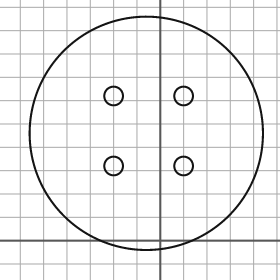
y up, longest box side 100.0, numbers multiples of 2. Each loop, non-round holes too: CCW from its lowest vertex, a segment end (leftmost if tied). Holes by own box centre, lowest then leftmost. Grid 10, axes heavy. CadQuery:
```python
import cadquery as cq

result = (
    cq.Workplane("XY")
    .moveTo(-6.0, 46.0)
    .circle(50.0)
    .moveTo(-20.0, 32.0)
    .circle(4.0)
    .moveTo(10.0, 32.0)
    .circle(4.0)
    .moveTo(-20.0, 62.0)
    .circle(4.0)
    .moveTo(10.0, 62.0)
    .circle(4.0)
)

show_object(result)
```